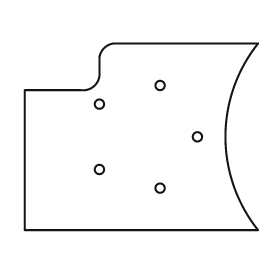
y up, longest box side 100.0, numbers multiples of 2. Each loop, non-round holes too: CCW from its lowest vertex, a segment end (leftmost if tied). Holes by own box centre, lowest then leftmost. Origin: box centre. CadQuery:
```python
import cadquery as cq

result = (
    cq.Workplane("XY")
    .moveTo(-50.0, -40.0)
    .lineTo(50.0, -40.0)
    .threePointArc((36.0, 0.0), (50.0, 40.0))
    .lineTo(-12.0, 40.0)
    .threePointArc((-16.0, 38.0), (-18.0, 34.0))
    .lineTo(-18.0, 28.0)
    .threePointArc((-20.0, 22.0), (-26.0, 20.0))
    .lineTo(-50.0, 20.0)
    .close()
    .moveTo(8.0, -22.0)
    .circle(2.0)
    .moveTo(-18.0, -14.0)
    .circle(2.0)
    .moveTo(24.0, 0.0)
    .circle(2.0)
    .moveTo(-18.0, 14.0)
    .circle(2.0)
    .moveTo(8.0, 22.0)
    .circle(2.0)
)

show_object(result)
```